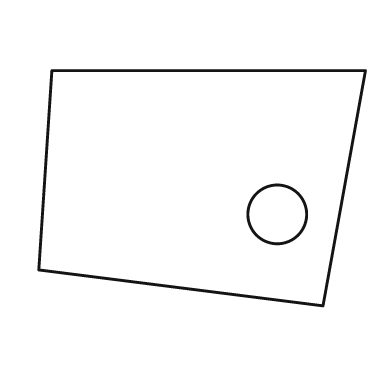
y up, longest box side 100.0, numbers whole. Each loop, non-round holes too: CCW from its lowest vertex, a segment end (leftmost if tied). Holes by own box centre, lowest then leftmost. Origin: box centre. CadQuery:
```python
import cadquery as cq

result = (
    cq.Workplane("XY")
    .moveTo(37.0, -36.0)
    .lineTo(50.0, 36.0)
    .lineTo(-46.0, 36.0)
    .lineTo(-50.0, -25.0)
    .close()
    .moveTo(23.0, -8.0)
    .circle(9.0)
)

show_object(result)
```